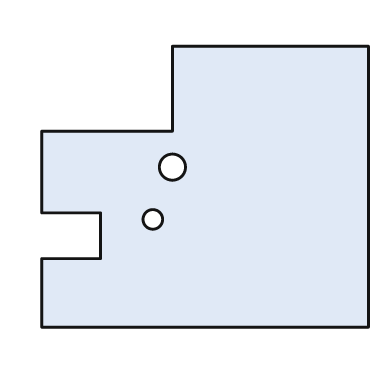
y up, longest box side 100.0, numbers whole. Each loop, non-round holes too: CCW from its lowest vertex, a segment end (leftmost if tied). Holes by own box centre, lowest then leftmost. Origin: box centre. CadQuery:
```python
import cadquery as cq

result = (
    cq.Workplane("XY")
    .moveTo(-50.0, -43.0)
    .lineTo(50.0, -43.0)
    .lineTo(50.0, 43.0)
    .lineTo(-10.0, 43.0)
    .lineTo(-10.0, 17.0)
    .lineTo(-50.0, 17.0)
    .lineTo(-50.0, -8.0)
    .lineTo(-32.0, -8.0)
    .lineTo(-32.0, -22.0)
    .lineTo(-50.0, -22.0)
    .close()
    .moveTo(-16.0, -10.0)
    .circle(3.0)
    .moveTo(-10.0, 6.0)
    .circle(4.0)
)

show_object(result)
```